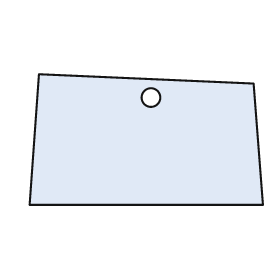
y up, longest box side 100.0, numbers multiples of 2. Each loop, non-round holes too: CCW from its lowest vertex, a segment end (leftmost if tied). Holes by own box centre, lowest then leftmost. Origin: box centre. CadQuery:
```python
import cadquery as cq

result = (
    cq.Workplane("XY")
    .moveTo(-50.0, -28.0)
    .lineTo(50.0, -28.0)
    .lineTo(46.0, 24.0)
    .lineTo(-46.0, 28.0)
    .close()
    .moveTo(2.0, 18.0)
    .circle(4.0)
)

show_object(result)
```